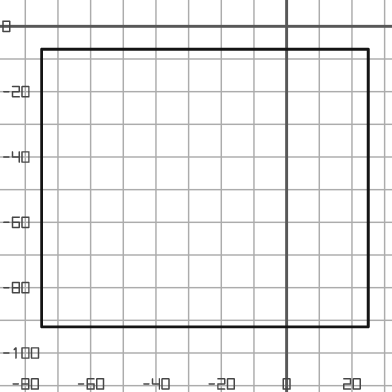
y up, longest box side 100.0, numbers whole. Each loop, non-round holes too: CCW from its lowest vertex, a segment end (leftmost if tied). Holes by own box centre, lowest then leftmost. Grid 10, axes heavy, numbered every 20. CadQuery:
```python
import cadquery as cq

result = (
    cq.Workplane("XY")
    .moveTo(-75.0, -92.0)
    .lineTo(25.0, -92.0)
    .lineTo(25.0, -7.0)
    .lineTo(-75.0, -7.0)
    .close()
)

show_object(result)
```